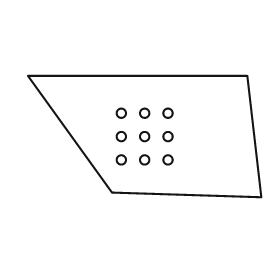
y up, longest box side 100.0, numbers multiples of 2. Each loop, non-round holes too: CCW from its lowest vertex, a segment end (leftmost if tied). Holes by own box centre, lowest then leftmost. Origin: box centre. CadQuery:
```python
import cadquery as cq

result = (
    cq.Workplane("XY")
    .moveTo(50.0, -26.0)
    .lineTo(44.0, 26.0)
    .lineTo(-50.0, 26.0)
    .lineTo(-14.0, -24.0)
    .close()
    .moveTo(-10.0, -10.0)
    .circle(2.0)
    .moveTo(0.0, -10.0)
    .circle(2.0)
    .moveTo(10.0, -10.0)
    .circle(2.0)
    .moveTo(-10.0, 0.0)
    .circle(2.0)
    .moveTo(0.0, 0.0)
    .circle(2.0)
    .moveTo(10.0, 0.0)
    .circle(2.0)
    .moveTo(-10.0, 10.0)
    .circle(2.0)
    .moveTo(0.0, 10.0)
    .circle(2.0)
    .moveTo(10.0, 10.0)
    .circle(2.0)
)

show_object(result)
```